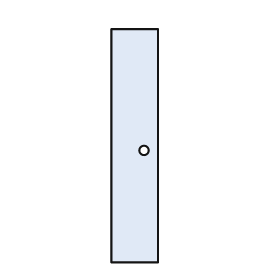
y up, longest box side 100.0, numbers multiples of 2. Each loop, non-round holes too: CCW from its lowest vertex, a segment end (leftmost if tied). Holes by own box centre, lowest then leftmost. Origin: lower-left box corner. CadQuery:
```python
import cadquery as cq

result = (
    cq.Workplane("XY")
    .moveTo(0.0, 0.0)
    .lineTo(20.0, 0.0)
    .lineTo(20.0, 100.0)
    .lineTo(0.0, 100.0)
    .close()
    .moveTo(14.0, 48.0)
    .circle(2.0)
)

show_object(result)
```